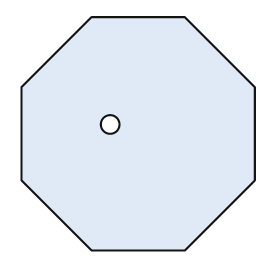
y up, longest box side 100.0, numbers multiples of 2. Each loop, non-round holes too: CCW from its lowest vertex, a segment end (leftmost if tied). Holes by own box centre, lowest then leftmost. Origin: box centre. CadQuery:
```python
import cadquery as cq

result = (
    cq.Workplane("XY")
    .moveTo(-20.0, -50.0)
    .lineTo(20.0, -50.0)
    .lineTo(50.0, -20.0)
    .lineTo(50.0, 20.0)
    .lineTo(20.0, 50.0)
    .lineTo(-20.0, 50.0)
    .lineTo(-50.0, 20.0)
    .lineTo(-50.0, -20.0)
    .close()
    .moveTo(-12.0, 4.0)
    .circle(4.0)
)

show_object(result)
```